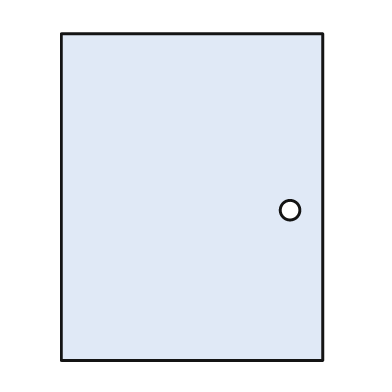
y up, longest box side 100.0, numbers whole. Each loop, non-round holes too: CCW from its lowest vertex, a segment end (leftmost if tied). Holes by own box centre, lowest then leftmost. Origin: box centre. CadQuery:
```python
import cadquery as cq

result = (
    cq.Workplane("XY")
    .moveTo(-40.0, -50.0)
    .lineTo(40.0, -50.0)
    .lineTo(40.0, 50.0)
    .lineTo(-40.0, 50.0)
    .close()
    .moveTo(30.0, -4.0)
    .circle(3.0)
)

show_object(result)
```